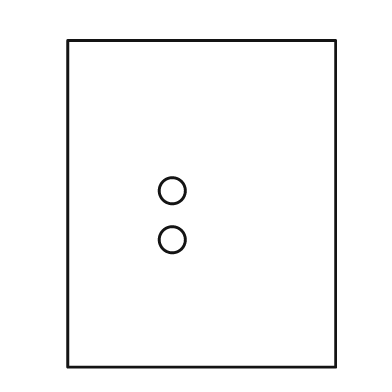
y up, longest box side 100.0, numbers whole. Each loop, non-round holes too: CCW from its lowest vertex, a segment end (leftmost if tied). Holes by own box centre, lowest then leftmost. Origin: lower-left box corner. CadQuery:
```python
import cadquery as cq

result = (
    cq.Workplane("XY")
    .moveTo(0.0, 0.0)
    .lineTo(82.0, 0.0)
    .lineTo(82.0, 100.0)
    .lineTo(0.0, 100.0)
    .close()
    .moveTo(32.0, 39.0)
    .circle(4.0)
    .moveTo(32.0, 54.0)
    .circle(4.0)
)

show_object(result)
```